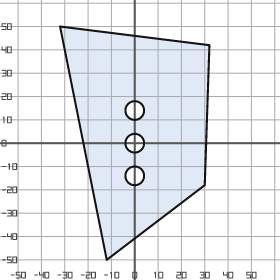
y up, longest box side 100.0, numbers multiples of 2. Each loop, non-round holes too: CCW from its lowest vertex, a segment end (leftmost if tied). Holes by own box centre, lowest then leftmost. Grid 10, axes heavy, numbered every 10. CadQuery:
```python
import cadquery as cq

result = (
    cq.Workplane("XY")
    .moveTo(-12.0, -50.0)
    .lineTo(30.0, -18.0)
    .lineTo(32.0, 42.0)
    .lineTo(-32.0, 50.0)
    .close()
    .moveTo(0.0, -14.0)
    .circle(4.0)
    .moveTo(0.0, 0.0)
    .circle(4.0)
    .moveTo(0.0, 14.0)
    .circle(4.0)
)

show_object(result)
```